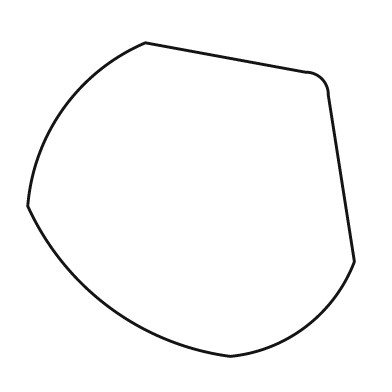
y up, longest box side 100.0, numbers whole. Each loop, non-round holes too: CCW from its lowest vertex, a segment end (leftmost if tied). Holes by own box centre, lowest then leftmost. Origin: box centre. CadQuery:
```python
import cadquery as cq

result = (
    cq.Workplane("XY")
    .moveTo(12.0, -48.0)
    .threePointArc((35.0, -39.0), (50.0, -19.0))
    .lineTo(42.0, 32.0)
    .threePointArc((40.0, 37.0), (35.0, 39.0))
    .lineTo(-14.0, 48.0)
    .threePointArc((-39.0, 28.0), (-50.0, -2.0))
    .threePointArc((-25.0, -33.0), (12.0, -48.0))
    .close()
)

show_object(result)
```